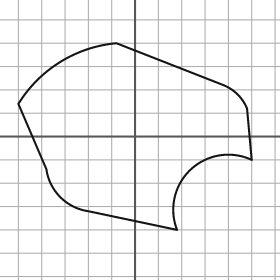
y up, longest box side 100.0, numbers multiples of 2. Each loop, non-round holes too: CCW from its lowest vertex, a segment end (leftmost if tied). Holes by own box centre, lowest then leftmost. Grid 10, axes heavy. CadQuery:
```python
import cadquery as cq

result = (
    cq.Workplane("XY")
    .moveTo(18.0, -40.0)
    .threePointArc((24.0, -14.0), (50.0, -10.0))
    .lineTo(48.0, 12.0)
    .threePointArc((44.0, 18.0), (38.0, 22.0))
    .lineTo(-8.0, 40.0)
    .threePointArc((-32.0, 32.0), (-50.0, 14.0))
    .lineTo(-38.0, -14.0)
    .threePointArc((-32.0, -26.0), (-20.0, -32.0))
    .close()
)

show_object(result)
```